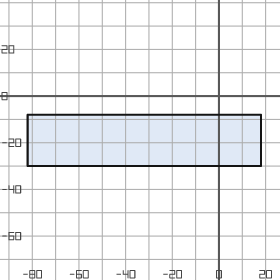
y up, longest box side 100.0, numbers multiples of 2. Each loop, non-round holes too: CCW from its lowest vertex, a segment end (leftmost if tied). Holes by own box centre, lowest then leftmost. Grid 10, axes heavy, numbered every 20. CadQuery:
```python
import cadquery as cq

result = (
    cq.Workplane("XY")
    .moveTo(-82.0, -30.0)
    .lineTo(18.0, -30.0)
    .lineTo(18.0, -8.0)
    .lineTo(-82.0, -8.0)
    .close()
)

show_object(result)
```